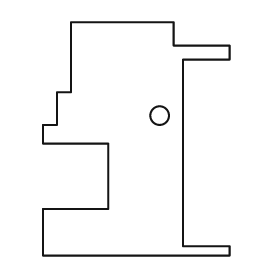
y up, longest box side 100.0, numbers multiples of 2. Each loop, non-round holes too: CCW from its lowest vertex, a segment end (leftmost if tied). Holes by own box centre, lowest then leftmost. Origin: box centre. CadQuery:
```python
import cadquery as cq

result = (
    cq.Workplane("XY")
    .moveTo(-40.0, -50.0)
    .lineTo(40.0, -50.0)
    .lineTo(40.0, -46.0)
    .lineTo(20.0, -46.0)
    .lineTo(20.0, 34.0)
    .lineTo(40.0, 34.0)
    .lineTo(40.0, 40.0)
    .lineTo(16.0, 40.0)
    .lineTo(16.0, 50.0)
    .lineTo(-28.0, 50.0)
    .lineTo(-28.0, 20.0)
    .lineTo(-34.0, 20.0)
    .lineTo(-34.0, 6.0)
    .lineTo(-40.0, 6.0)
    .lineTo(-40.0, -2.0)
    .lineTo(-12.0, -2.0)
    .lineTo(-12.0, -30.0)
    .lineTo(-40.0, -30.0)
    .close()
    .moveTo(10.0, 10.0)
    .circle(4.0)
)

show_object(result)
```